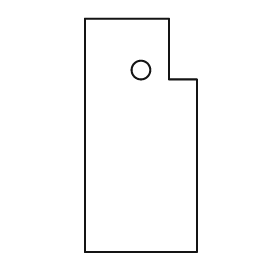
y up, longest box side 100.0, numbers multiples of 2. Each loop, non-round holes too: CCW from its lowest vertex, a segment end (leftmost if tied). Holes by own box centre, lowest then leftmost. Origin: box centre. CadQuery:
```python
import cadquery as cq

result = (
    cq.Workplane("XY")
    .moveTo(-24.0, -50.0)
    .lineTo(24.0, -50.0)
    .lineTo(24.0, 24.0)
    .lineTo(12.0, 24.0)
    .lineTo(12.0, 50.0)
    .lineTo(-24.0, 50.0)
    .close()
    .moveTo(0.0, 28.0)
    .circle(4.0)
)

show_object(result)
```